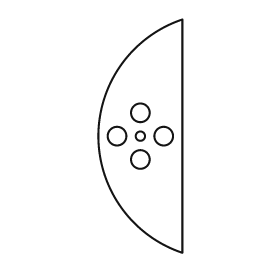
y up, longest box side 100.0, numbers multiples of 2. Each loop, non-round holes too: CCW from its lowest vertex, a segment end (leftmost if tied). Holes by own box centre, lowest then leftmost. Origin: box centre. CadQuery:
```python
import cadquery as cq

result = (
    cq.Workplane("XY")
    .moveTo(18.0, -50.0)
    .lineTo(18.0, 50.0)
    .threePointArc((-18.0, 0.0), (18.0, -50.0))
    .close()
    .moveTo(0.0, -10.0)
    .circle(4.0)
    .moveTo(-10.0, 0.0)
    .circle(4.0)
    .moveTo(0.0, 0.0)
    .circle(2.0)
    .moveTo(10.0, 0.0)
    .circle(4.0)
    .moveTo(0.0, 10.0)
    .circle(4.0)
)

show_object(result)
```